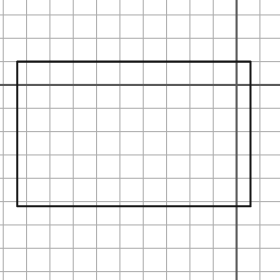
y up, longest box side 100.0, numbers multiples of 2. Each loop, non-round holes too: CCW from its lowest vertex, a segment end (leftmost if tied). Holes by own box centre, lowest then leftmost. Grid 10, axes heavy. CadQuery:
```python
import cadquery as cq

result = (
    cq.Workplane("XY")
    .moveTo(-94.0, -52.0)
    .lineTo(6.0, -52.0)
    .lineTo(6.0, 10.0)
    .lineTo(-94.0, 10.0)
    .close()
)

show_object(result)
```